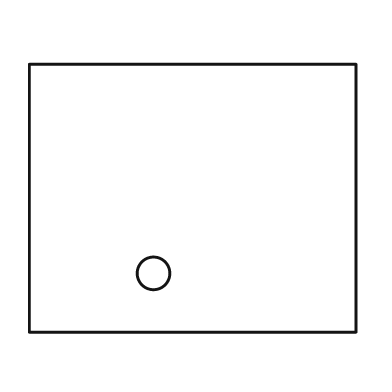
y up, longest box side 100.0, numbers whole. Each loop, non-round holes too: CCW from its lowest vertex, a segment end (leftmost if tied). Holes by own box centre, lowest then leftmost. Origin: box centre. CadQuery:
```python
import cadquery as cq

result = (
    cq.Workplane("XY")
    .moveTo(-50.0, -41.0)
    .lineTo(50.0, -41.0)
    .lineTo(50.0, 41.0)
    .lineTo(-50.0, 41.0)
    .close()
    .moveTo(-12.0, -23.0)
    .circle(5.0)
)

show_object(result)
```